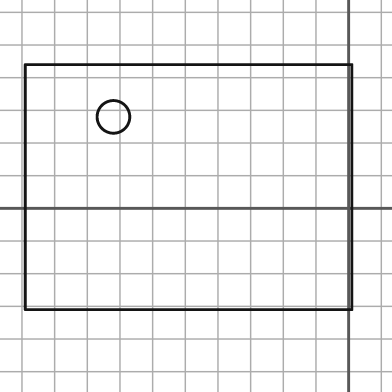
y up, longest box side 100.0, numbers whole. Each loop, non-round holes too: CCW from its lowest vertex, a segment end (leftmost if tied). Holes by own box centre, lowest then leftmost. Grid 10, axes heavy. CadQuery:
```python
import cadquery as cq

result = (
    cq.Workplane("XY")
    .moveTo(-99.0, -31.0)
    .lineTo(1.0, -31.0)
    .lineTo(1.0, 44.0)
    .lineTo(-99.0, 44.0)
    .close()
    .moveTo(-72.0, 28.0)
    .circle(5.0)
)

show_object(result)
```